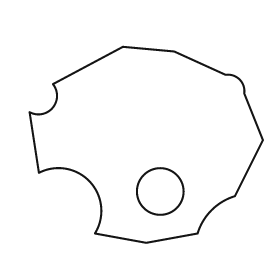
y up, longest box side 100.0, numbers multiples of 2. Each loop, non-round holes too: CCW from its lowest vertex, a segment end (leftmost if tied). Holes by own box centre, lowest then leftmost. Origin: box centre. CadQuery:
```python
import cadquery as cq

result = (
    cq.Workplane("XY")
    .moveTo(0.0, -42.0)
    .lineTo(22.0, -38.0)
    .threePointArc((28.0, -28.0), (38.0, -22.0))
    .lineTo(50.0, 2.0)
    .lineTo(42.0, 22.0)
    .threePointArc((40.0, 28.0), (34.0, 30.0))
    .lineTo(12.0, 40.0)
    .lineTo(-10.0, 42.0)
    .lineTo(-40.0, 26.0)
    .threePointArc((-40.0, 16.0), (-50.0, 14.0))
    .lineTo(-46.0, -12.0)
    .threePointArc((-24.0, -16.0), (-22.0, -38.0))
    .close()
    .moveTo(6.0, -20.0)
    .circle(10.0)
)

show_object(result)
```